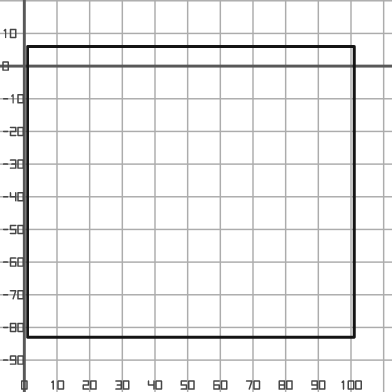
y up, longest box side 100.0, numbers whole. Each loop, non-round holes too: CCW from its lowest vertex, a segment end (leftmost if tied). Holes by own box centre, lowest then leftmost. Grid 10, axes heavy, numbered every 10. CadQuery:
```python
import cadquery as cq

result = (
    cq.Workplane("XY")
    .moveTo(1.0, -83.0)
    .lineTo(101.0, -83.0)
    .lineTo(101.0, 6.0)
    .lineTo(1.0, 6.0)
    .close()
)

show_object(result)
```